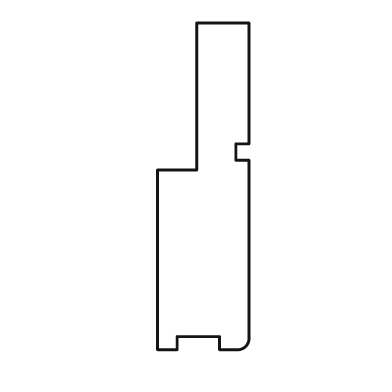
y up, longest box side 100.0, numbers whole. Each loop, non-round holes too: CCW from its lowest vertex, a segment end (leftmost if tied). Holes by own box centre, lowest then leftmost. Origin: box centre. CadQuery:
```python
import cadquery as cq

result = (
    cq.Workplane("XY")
    .moveTo(-14.0, -50.0)
    .lineTo(-8.0, -50.0)
    .lineTo(-8.0, -46.0)
    .lineTo(5.0, -46.0)
    .lineTo(5.0, -50.0)
    .lineTo(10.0, -50.0)
    .threePointArc((13.0, -49.0), (14.0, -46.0))
    .lineTo(14.0, 8.0)
    .lineTo(10.0, 8.0)
    .lineTo(10.0, 13.0)
    .lineTo(14.0, 13.0)
    .lineTo(14.0, 50.0)
    .lineTo(-2.0, 50.0)
    .lineTo(-2.0, 5.0)
    .lineTo(-14.0, 5.0)
    .close()
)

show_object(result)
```